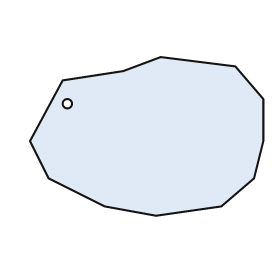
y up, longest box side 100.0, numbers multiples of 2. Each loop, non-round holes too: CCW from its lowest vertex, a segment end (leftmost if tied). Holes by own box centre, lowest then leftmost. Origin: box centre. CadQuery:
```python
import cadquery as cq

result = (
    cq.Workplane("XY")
    .moveTo(4.0, -34.0)
    .lineTo(32.0, -30.0)
    .lineTo(46.0, -18.0)
    .lineTo(50.0, -2.0)
    .lineTo(50.0, 16.0)
    .lineTo(38.0, 30.0)
    .lineTo(6.0, 34.0)
    .lineTo(-10.0, 28.0)
    .lineTo(-36.0, 24.0)
    .lineTo(-50.0, -2.0)
    .lineTo(-42.0, -18.0)
    .lineTo(-18.0, -30.0)
    .close()
    .moveTo(-34.0, 14.0)
    .circle(2.0)
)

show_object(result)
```